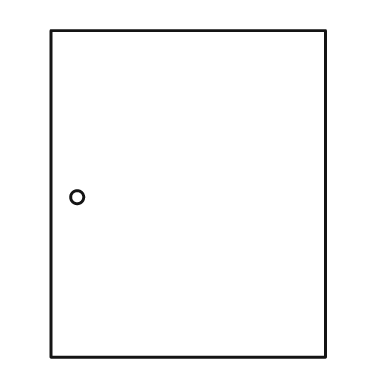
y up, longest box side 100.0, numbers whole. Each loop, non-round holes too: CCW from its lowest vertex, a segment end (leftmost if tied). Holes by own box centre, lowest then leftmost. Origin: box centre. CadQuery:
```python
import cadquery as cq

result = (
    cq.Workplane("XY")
    .moveTo(-42.0, -50.0)
    .lineTo(42.0, -50.0)
    .lineTo(42.0, 50.0)
    .lineTo(-42.0, 50.0)
    .close()
    .moveTo(-34.0, -1.0)
    .circle(2.0)
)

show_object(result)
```